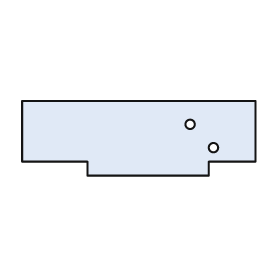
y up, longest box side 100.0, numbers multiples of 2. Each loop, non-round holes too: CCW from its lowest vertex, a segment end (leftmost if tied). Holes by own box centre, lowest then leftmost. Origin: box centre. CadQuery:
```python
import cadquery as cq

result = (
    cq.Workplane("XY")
    .moveTo(-22.0, -16.0)
    .lineTo(30.0, -16.0)
    .lineTo(30.0, -10.0)
    .lineTo(50.0, -10.0)
    .lineTo(50.0, 16.0)
    .lineTo(-50.0, 16.0)
    .lineTo(-50.0, -10.0)
    .lineTo(-22.0, -10.0)
    .close()
    .moveTo(32.0, -4.0)
    .circle(2.0)
    .moveTo(22.0, 6.0)
    .circle(2.0)
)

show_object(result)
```